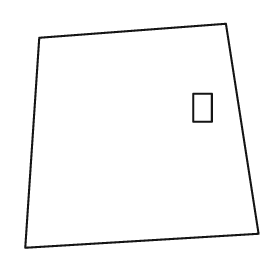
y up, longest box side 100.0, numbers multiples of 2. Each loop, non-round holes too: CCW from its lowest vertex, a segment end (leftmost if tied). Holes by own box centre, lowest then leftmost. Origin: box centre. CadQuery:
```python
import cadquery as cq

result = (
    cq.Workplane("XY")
    .moveTo(-50.0, -48.0)
    .lineTo(50.0, -42.0)
    .lineTo(36.0, 48.0)
    .lineTo(-44.0, 42.0)
    .close()
    .moveTo(22.0, 6.0)
    .lineTo(30.0, 6.0)
    .lineTo(30.0, 18.0)
    .lineTo(22.0, 18.0)
    .close()
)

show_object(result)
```